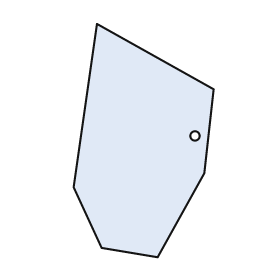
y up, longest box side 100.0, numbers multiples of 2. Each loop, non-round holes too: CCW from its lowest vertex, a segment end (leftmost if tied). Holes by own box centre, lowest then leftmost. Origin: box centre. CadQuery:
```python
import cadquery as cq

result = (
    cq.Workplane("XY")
    .moveTo(6.0, -50.0)
    .lineTo(26.0, -14.0)
    .lineTo(30.0, 22.0)
    .lineTo(-20.0, 50.0)
    .lineTo(-30.0, -20.0)
    .lineTo(-18.0, -46.0)
    .close()
    .moveTo(22.0, 2.0)
    .circle(2.0)
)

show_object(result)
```